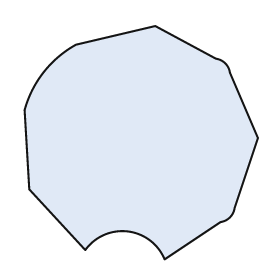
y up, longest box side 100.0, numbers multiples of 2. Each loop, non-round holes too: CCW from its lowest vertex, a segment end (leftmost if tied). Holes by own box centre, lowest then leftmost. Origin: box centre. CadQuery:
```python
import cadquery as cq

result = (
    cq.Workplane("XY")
    .moveTo(10.0, -50.0)
    .lineTo(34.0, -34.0)
    .threePointArc((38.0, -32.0), (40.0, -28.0))
    .lineTo(50.0, 2.0)
    .lineTo(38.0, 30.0)
    .threePointArc((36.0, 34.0), (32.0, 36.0))
    .lineTo(6.0, 50.0)
    .lineTo(-28.0, 42.0)
    .threePointArc((-42.0, 30.0), (-50.0, 14.0))
    .lineTo(-48.0, -20.0)
    .lineTo(-24.0, -46.0)
    .threePointArc((-6.0, -38.0), (10.0, -50.0))
    .close()
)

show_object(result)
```